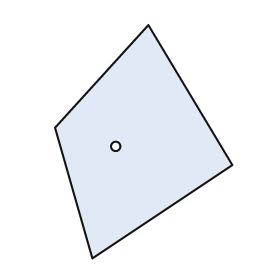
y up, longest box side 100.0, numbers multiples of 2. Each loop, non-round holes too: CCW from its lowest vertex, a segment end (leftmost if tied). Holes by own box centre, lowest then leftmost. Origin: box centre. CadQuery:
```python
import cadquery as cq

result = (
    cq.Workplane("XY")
    .moveTo(-22.0, -50.0)
    .lineTo(38.0, -10.0)
    .lineTo(2.0, 50.0)
    .lineTo(-38.0, 6.0)
    .close()
    .moveTo(-12.0, -2.0)
    .circle(2.0)
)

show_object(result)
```